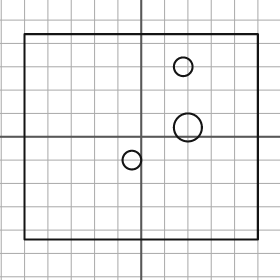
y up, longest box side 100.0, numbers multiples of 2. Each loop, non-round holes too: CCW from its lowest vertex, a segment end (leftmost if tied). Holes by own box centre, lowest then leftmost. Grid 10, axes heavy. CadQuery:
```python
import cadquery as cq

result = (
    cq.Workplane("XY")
    .moveTo(-50.0, -44.0)
    .lineTo(50.0, -44.0)
    .lineTo(50.0, 44.0)
    .lineTo(-50.0, 44.0)
    .close()
    .moveTo(-4.0, -10.0)
    .circle(4.0)
    .moveTo(20.0, 4.0)
    .circle(6.0)
    .moveTo(18.0, 30.0)
    .circle(4.0)
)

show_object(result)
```